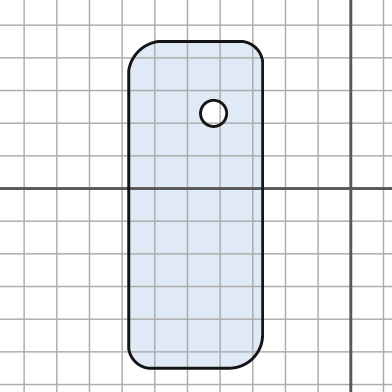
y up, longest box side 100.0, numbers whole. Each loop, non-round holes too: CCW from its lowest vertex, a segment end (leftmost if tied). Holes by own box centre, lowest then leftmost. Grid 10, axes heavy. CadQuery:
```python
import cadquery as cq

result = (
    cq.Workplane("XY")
    .moveTo(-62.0, -55.0)
    .lineTo(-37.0, -55.0)
    .threePointArc((-30.0, -52.0), (-27.0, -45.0))
    .lineTo(-27.0, 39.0)
    .threePointArc((-29.0, 43.0), (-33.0, 45.0))
    .lineTo(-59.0, 45.0)
    .threePointArc((-65.0, 42.0), (-68.0, 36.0))
    .lineTo(-68.0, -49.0)
    .threePointArc((-66.0, -53.0), (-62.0, -55.0))
    .close()
    .moveTo(-42.0, 23.0)
    .circle(4.0)
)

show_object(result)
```